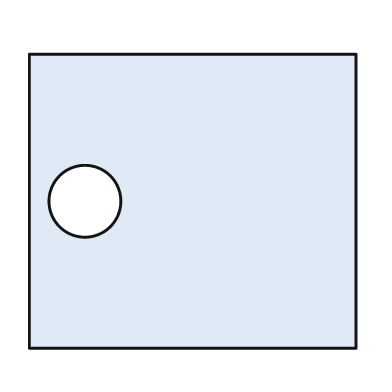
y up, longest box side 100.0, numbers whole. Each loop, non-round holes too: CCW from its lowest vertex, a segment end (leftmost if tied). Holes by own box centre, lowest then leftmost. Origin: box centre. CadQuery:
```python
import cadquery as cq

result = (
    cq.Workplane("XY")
    .moveTo(-50.0, -45.0)
    .lineTo(50.0, -45.0)
    .lineTo(50.0, 45.0)
    .lineTo(-50.0, 45.0)
    .close()
    .moveTo(-33.0, 0.0)
    .circle(11.0)
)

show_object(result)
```